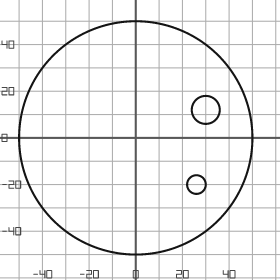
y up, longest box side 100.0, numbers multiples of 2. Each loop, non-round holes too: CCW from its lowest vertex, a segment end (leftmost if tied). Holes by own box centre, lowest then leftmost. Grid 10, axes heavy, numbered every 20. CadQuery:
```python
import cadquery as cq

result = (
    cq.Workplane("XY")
    .moveTo(0.0, 0.0)
    .circle(50.0)
    .moveTo(26.0, -20.0)
    .circle(4.0)
    .moveTo(30.0, 12.0)
    .circle(6.0)
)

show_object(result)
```